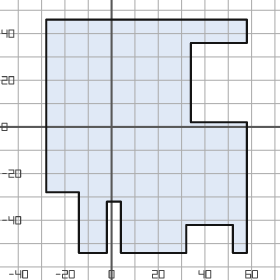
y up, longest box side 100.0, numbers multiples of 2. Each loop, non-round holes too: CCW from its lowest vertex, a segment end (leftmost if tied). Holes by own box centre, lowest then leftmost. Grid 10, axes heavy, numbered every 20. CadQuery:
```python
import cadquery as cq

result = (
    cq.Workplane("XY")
    .moveTo(-14.0, -54.0)
    .lineTo(-2.0, -54.0)
    .lineTo(-2.0, -32.0)
    .lineTo(4.0, -32.0)
    .lineTo(4.0, -54.0)
    .lineTo(32.0, -54.0)
    .lineTo(32.0, -42.0)
    .lineTo(52.0, -42.0)
    .lineTo(52.0, -54.0)
    .lineTo(58.0, -54.0)
    .lineTo(58.0, 2.0)
    .lineTo(34.0, 2.0)
    .lineTo(34.0, 36.0)
    .lineTo(58.0, 36.0)
    .lineTo(58.0, 46.0)
    .lineTo(-28.0, 46.0)
    .lineTo(-28.0, -28.0)
    .lineTo(-14.0, -28.0)
    .close()
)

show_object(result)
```